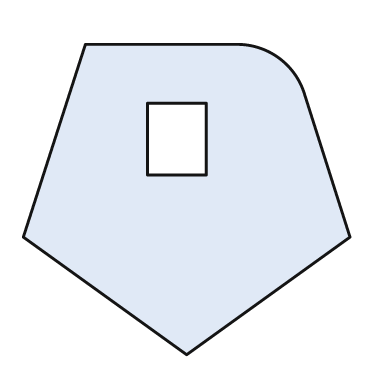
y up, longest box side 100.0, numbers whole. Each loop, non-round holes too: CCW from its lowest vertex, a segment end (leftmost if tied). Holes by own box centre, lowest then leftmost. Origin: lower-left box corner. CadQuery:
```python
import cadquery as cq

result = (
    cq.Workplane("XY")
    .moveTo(50.0, 0.0)
    .lineTo(100.0, 36.0)
    .lineTo(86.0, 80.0)
    .threePointArc((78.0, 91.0), (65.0, 95.0))
    .lineTo(19.0, 95.0)
    .lineTo(0.0, 36.0)
    .close()
    .moveTo(38.0, 55.0)
    .lineTo(56.0, 55.0)
    .lineTo(56.0, 77.0)
    .lineTo(38.0, 77.0)
    .close()
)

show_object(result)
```